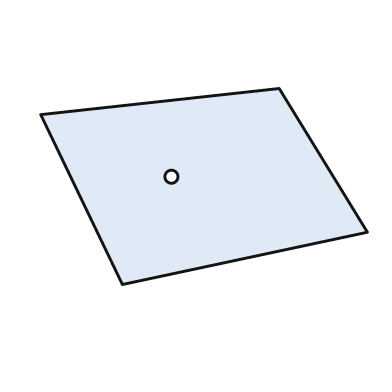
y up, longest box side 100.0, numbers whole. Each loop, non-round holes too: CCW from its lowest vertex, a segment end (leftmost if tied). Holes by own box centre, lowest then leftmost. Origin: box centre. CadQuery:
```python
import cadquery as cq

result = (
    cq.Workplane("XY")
    .moveTo(-25.0, -30.0)
    .lineTo(50.0, -14.0)
    .lineTo(23.0, 30.0)
    .lineTo(-50.0, 22.0)
    .close()
    .moveTo(-10.0, 3.0)
    .circle(2.0)
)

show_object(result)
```